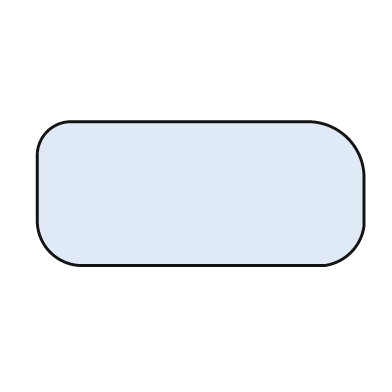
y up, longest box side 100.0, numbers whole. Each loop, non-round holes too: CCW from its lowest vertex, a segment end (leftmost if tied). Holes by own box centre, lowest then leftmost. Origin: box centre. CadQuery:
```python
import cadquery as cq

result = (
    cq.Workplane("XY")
    .moveTo(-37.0, -22.0)
    .lineTo(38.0, -22.0)
    .threePointArc((46.0, -18.0), (50.0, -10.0))
    .lineTo(50.0, 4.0)
    .threePointArc((45.0, 17.0), (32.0, 22.0))
    .lineTo(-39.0, 22.0)
    .threePointArc((-47.0, 19.0), (-50.0, 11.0))
    .lineTo(-50.0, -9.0)
    .threePointArc((-46.0, -18.0), (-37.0, -22.0))
    .close()
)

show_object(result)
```